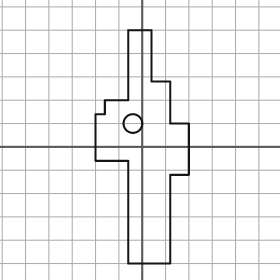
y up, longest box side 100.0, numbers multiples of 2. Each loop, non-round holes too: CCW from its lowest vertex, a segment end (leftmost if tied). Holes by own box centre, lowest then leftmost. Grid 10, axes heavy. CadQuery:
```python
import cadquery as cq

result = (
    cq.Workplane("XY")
    .moveTo(-6.0, -50.0)
    .lineTo(12.0, -50.0)
    .lineTo(12.0, -12.0)
    .lineTo(20.0, -12.0)
    .lineTo(20.0, 10.0)
    .lineTo(12.0, 10.0)
    .lineTo(12.0, 28.0)
    .lineTo(4.0, 28.0)
    .lineTo(4.0, 50.0)
    .lineTo(-6.0, 50.0)
    .lineTo(-6.0, 20.0)
    .lineTo(-16.0, 20.0)
    .lineTo(-16.0, 14.0)
    .lineTo(-20.0, 14.0)
    .lineTo(-20.0, -6.0)
    .lineTo(-6.0, -6.0)
    .close()
    .moveTo(-4.0, 10.0)
    .circle(4.0)
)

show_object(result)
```